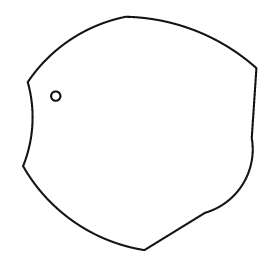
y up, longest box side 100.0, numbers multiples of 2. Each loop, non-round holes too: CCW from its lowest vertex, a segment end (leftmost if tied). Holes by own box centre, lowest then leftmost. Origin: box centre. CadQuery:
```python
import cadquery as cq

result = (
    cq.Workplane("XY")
    .moveTo(2.0, -50.0)
    .lineTo(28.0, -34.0)
    .threePointArc((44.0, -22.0), (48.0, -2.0))
    .lineTo(50.0, 28.0)
    .threePointArc((24.0, 44.0), (-6.0, 50.0))
    .threePointArc((-30.0, 40.0), (-48.0, 22.0))
    .threePointArc((-46.0, 4.0), (-50.0, -14.0))
    .threePointArc((-28.0, -38.0), (2.0, -50.0))
    .close()
    .moveTo(-36.0, 16.0)
    .circle(2.0)
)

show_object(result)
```